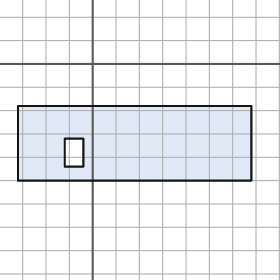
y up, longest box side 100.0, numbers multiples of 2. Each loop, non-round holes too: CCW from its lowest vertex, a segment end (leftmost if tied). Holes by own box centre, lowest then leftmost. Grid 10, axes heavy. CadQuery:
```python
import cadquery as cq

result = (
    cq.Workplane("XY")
    .moveTo(-32.0, -50.0)
    .lineTo(68.0, -50.0)
    .lineTo(68.0, -18.0)
    .lineTo(-32.0, -18.0)
    .close()
    .moveTo(-12.0, -44.0)
    .lineTo(-4.0, -44.0)
    .lineTo(-4.0, -32.0)
    .lineTo(-12.0, -32.0)
    .close()
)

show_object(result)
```